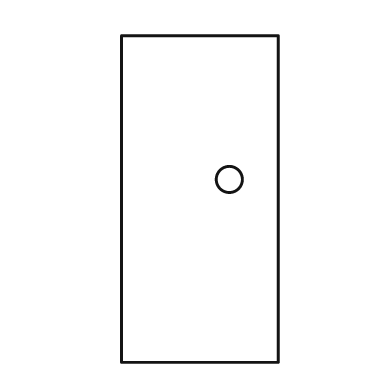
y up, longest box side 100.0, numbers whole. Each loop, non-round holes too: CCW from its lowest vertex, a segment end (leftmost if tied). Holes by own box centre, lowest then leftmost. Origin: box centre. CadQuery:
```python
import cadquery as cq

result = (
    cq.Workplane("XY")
    .moveTo(-24.0, -50.0)
    .lineTo(24.0, -50.0)
    .lineTo(24.0, 50.0)
    .lineTo(-24.0, 50.0)
    .close()
    .moveTo(9.0, 6.0)
    .circle(4.0)
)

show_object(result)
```